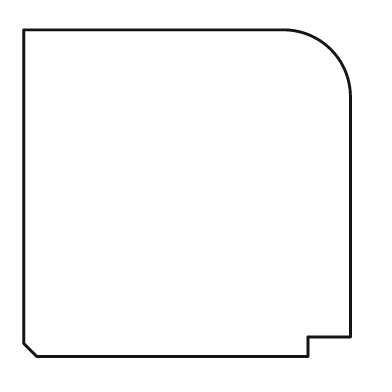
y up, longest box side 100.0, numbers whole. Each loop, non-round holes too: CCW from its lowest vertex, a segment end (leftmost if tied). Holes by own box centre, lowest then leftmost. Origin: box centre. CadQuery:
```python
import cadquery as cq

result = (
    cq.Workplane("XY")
    .moveTo(-46.0, -50.0)
    .lineTo(37.0, -50.0)
    .lineTo(37.0, -44.0)
    .lineTo(50.0, -44.0)
    .lineTo(50.0, 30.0)
    .threePointArc((44.0, 44.0), (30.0, 50.0))
    .lineTo(-50.0, 50.0)
    .lineTo(-50.0, -46.0)
    .close()
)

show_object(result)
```